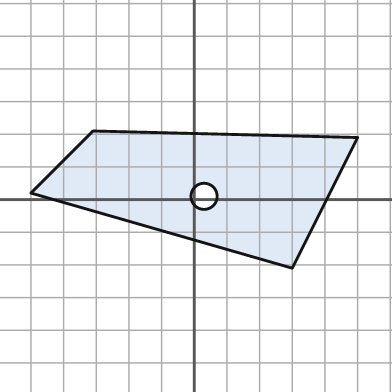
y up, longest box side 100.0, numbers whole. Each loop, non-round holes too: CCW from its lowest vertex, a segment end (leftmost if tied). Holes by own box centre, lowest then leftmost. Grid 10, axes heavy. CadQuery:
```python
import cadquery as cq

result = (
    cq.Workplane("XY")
    .moveTo(30.0, -21.0)
    .lineTo(50.0, 19.0)
    .lineTo(-31.0, 21.0)
    .lineTo(-50.0, 2.0)
    .close()
    .moveTo(3.0, 1.0)
    .circle(4.0)
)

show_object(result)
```